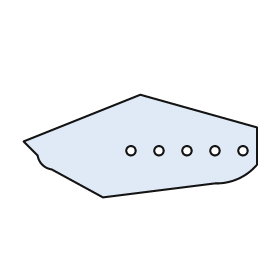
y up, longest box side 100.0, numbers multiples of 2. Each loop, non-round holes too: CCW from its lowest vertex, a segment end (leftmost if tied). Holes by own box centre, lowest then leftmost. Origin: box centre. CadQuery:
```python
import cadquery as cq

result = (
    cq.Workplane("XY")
    .moveTo(-16.0, -22.0)
    .lineTo(32.0, -16.0)
    .threePointArc((42.0, -14.0), (50.0, -8.0))
    .lineTo(50.0, 8.0)
    .lineTo(0.0, 22.0)
    .lineTo(-50.0, 2.0)
    .lineTo(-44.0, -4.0)
    .threePointArc((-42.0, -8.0), (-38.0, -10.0))
    .close()
    .moveTo(-4.0, -2.0)
    .circle(2.0)
    .moveTo(8.0, -2.0)
    .circle(2.0)
    .moveTo(20.0, -2.0)
    .circle(2.0)
    .moveTo(32.0, -2.0)
    .circle(2.0)
    .moveTo(44.0, -2.0)
    .circle(2.0)
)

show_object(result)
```